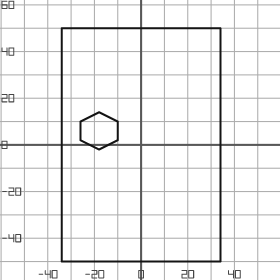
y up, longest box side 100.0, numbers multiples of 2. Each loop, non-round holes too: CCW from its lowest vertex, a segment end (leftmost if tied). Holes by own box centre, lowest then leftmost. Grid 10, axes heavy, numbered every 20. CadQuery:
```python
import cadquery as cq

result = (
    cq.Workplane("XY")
    .moveTo(-34.0, -50.0)
    .lineTo(34.0, -50.0)
    .lineTo(34.0, 50.0)
    .lineTo(-34.0, 50.0)
    .close()
    .moveTo(-18.0, -2.0)
    .lineTo(-10.0, 2.0)
    .lineTo(-10.0, 10.0)
    .lineTo(-18.0, 14.0)
    .lineTo(-26.0, 10.0)
    .lineTo(-26.0, 2.0)
    .close()
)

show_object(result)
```